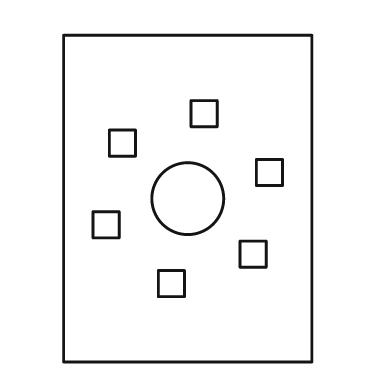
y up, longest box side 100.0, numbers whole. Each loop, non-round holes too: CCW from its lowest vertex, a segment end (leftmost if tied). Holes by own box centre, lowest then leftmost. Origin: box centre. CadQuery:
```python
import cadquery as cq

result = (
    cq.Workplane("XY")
    .moveTo(-38.0, -50.0)
    .lineTo(38.0, -50.0)
    .lineTo(38.0, 50.0)
    .lineTo(-38.0, 50.0)
    .close()
    .moveTo(-9.0, -30.0)
    .lineTo(-1.0, -30.0)
    .lineTo(-1.0, -22.0)
    .lineTo(-9.0, -22.0)
    .close()
    .moveTo(16.0, -21.0)
    .lineTo(24.0, -21.0)
    .lineTo(24.0, -13.0)
    .lineTo(16.0, -13.0)
    .close()
    .moveTo(-29.0, -12.0)
    .lineTo(-21.0, -12.0)
    .lineTo(-21.0, -4.0)
    .lineTo(-29.0, -4.0)
    .close()
    .moveTo(0.0, 0.0)
    .circle(11.0)
    .moveTo(21.0, 4.0)
    .lineTo(29.0, 4.0)
    .lineTo(29.0, 12.0)
    .lineTo(21.0, 12.0)
    .close()
    .moveTo(-24.0, 13.0)
    .lineTo(-16.0, 13.0)
    .lineTo(-16.0, 21.0)
    .lineTo(-24.0, 21.0)
    .close()
    .moveTo(1.0, 22.0)
    .lineTo(9.0, 22.0)
    .lineTo(9.0, 30.0)
    .lineTo(1.0, 30.0)
    .close()
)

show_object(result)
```